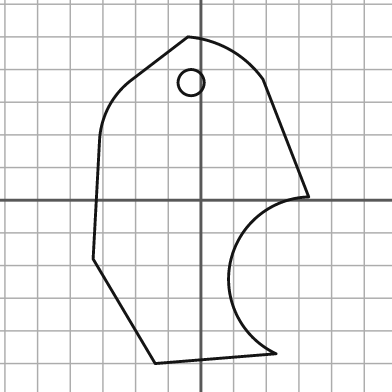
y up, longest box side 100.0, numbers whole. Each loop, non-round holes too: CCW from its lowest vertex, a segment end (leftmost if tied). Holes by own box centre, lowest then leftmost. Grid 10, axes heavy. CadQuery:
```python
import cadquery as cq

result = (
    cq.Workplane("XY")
    .moveTo(-14.0, -50.0)
    .lineTo(23.0, -47.0)
    .threePointArc((9.0, -19.0), (33.0, 1.0))
    .lineTo(19.0, 37.0)
    .threePointArc((9.0, 46.0), (-4.0, 50.0))
    .lineTo(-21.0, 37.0)
    .threePointArc((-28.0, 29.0), (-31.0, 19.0))
    .lineTo(-33.0, -18.0)
    .close()
    .moveTo(-3.0, 36.0)
    .circle(4.0)
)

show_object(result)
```